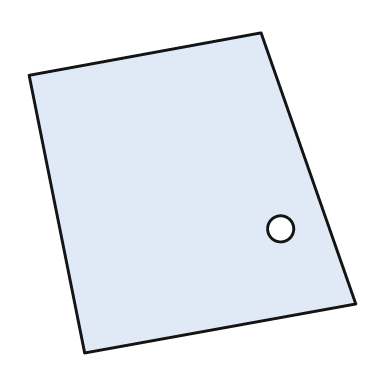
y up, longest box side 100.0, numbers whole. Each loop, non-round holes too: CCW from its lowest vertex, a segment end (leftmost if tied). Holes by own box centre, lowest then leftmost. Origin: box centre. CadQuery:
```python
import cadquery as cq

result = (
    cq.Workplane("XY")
    .moveTo(-33.0, -49.0)
    .lineTo(50.0, -34.0)
    .lineTo(21.0, 49.0)
    .lineTo(-50.0, 36.0)
    .close()
    .moveTo(27.0, -11.0)
    .circle(4.0)
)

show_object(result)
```